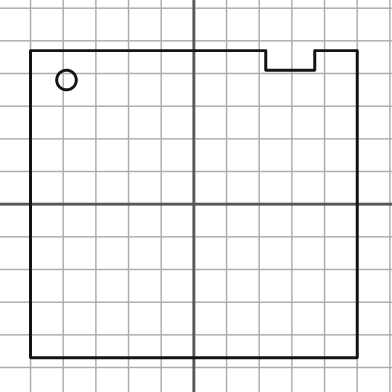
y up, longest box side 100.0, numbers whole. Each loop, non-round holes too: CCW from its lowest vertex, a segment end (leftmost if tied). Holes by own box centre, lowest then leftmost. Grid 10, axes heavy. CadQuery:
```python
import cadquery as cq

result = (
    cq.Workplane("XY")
    .moveTo(-50.0, -47.0)
    .lineTo(50.0, -47.0)
    .lineTo(50.0, 47.0)
    .lineTo(37.0, 47.0)
    .lineTo(37.0, 41.0)
    .lineTo(22.0, 41.0)
    .lineTo(22.0, 47.0)
    .lineTo(-50.0, 47.0)
    .close()
    .moveTo(-39.0, 38.0)
    .circle(3.0)
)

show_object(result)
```